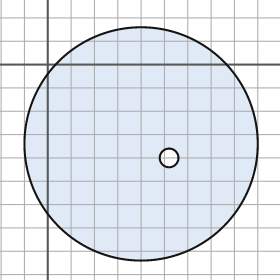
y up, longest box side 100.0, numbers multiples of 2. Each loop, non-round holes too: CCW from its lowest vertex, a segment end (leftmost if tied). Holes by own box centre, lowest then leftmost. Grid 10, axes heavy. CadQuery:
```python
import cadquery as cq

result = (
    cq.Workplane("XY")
    .moveTo(40.0, -34.0)
    .circle(50.0)
    .moveTo(52.0, -40.0)
    .circle(4.0)
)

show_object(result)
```